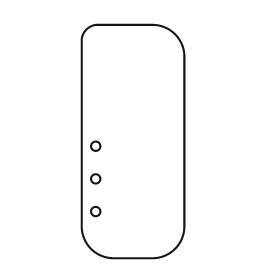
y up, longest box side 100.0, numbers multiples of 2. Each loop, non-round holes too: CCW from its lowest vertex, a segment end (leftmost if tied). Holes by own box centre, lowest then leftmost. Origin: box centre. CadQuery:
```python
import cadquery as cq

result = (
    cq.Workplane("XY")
    .moveTo(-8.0, -50.0)
    .lineTo(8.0, -50.0)
    .threePointArc((18.0, -46.0), (22.0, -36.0))
    .lineTo(22.0, 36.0)
    .threePointArc((18.0, 46.0), (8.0, 50.0))
    .lineTo(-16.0, 50.0)
    .threePointArc((-20.0, 48.0), (-22.0, 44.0))
    .lineTo(-22.0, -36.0)
    .threePointArc((-18.0, -46.0), (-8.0, -50.0))
    .close()
    .moveTo(-16.0, -30.0)
    .circle(2.0)
    .moveTo(-16.0, -16.0)
    .circle(2.0)
    .moveTo(-16.0, -2.0)
    .circle(2.0)
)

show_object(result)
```